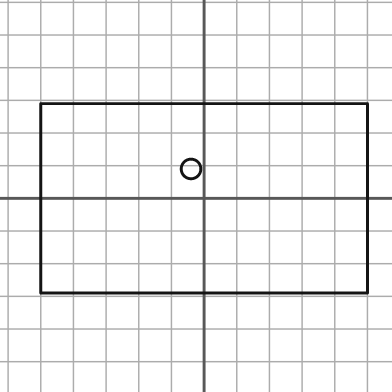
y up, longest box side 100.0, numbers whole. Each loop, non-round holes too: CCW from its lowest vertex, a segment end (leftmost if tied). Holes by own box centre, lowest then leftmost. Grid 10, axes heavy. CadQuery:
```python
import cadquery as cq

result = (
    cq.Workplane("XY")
    .moveTo(-50.0, -29.0)
    .lineTo(50.0, -29.0)
    .lineTo(50.0, 29.0)
    .lineTo(-50.0, 29.0)
    .close()
    .moveTo(-4.0, 9.0)
    .circle(3.0)
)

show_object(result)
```